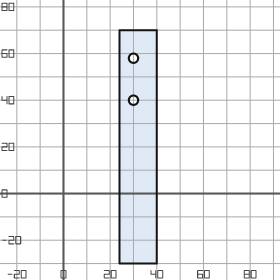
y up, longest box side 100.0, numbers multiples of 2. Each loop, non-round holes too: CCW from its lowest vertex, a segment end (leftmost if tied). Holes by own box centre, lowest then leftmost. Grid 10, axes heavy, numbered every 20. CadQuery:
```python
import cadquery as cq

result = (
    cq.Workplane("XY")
    .moveTo(24.0, -30.0)
    .lineTo(40.0, -30.0)
    .lineTo(40.0, 70.0)
    .lineTo(24.0, 70.0)
    .close()
    .moveTo(30.0, 40.0)
    .circle(2.0)
    .moveTo(30.0, 58.0)
    .circle(2.0)
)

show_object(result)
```